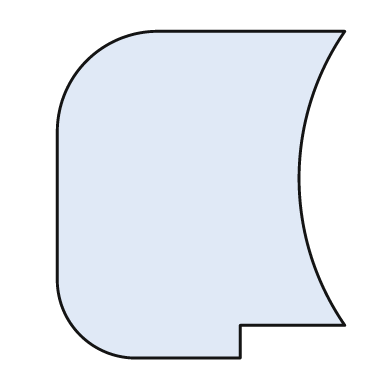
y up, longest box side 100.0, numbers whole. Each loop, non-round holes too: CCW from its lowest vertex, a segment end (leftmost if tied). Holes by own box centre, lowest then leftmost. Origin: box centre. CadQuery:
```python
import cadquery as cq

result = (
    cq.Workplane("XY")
    .moveTo(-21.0, -50.0)
    .lineTo(12.0, -50.0)
    .lineTo(12.0, -40.0)
    .lineTo(44.0, -40.0)
    .threePointArc((30.0, 5.0), (44.0, 50.0))
    .lineTo(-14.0, 50.0)
    .threePointArc((-35.0, 41.0), (-44.0, 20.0))
    .lineTo(-44.0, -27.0)
    .threePointArc((-37.0, -43.0), (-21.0, -50.0))
    .close()
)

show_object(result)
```